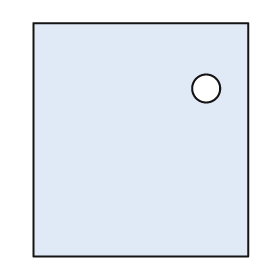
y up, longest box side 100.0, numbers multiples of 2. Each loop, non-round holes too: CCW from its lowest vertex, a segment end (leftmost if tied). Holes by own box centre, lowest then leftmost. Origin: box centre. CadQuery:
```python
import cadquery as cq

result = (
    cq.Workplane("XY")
    .moveTo(-46.0, -50.0)
    .lineTo(46.0, -50.0)
    .lineTo(46.0, 50.0)
    .lineTo(-46.0, 50.0)
    .close()
    .moveTo(28.0, 22.0)
    .circle(6.0)
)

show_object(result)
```